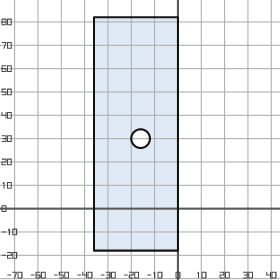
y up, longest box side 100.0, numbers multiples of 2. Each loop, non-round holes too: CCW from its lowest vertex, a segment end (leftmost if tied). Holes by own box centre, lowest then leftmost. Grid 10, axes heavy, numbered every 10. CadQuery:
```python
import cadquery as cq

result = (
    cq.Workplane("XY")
    .moveTo(-36.0, -18.0)
    .lineTo(0.0, -18.0)
    .lineTo(0.0, 82.0)
    .lineTo(-36.0, 82.0)
    .close()
    .moveTo(-16.0, 30.0)
    .circle(4.0)
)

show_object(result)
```